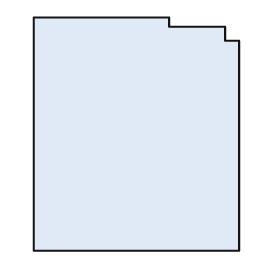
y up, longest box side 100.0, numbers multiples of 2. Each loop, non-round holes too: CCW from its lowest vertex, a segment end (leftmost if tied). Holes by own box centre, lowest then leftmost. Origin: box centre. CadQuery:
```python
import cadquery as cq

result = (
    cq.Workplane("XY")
    .moveTo(-44.0, -50.0)
    .lineTo(44.0, -50.0)
    .lineTo(44.0, 40.0)
    .lineTo(38.0, 40.0)
    .lineTo(38.0, 46.0)
    .lineTo(14.0, 46.0)
    .lineTo(14.0, 50.0)
    .lineTo(-44.0, 50.0)
    .close()
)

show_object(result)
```